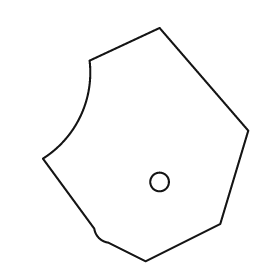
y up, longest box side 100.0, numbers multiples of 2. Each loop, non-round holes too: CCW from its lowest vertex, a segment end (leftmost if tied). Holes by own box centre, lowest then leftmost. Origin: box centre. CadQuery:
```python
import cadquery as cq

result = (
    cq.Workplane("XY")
    .moveTo(0.0, -50.0)
    .lineTo(32.0, -34.0)
    .lineTo(44.0, 6.0)
    .lineTo(6.0, 50.0)
    .lineTo(-24.0, 36.0)
    .threePointArc((-28.0, 12.0), (-44.0, -6.0))
    .lineTo(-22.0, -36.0)
    .threePointArc((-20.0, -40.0), (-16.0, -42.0))
    .close()
    .moveTo(6.0, -16.0)
    .circle(4.0)
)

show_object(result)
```